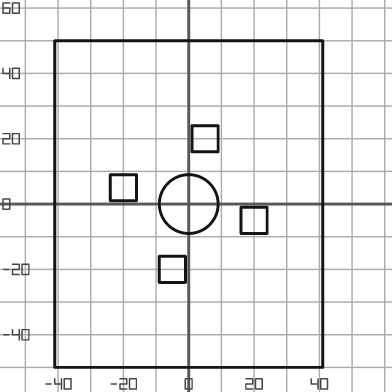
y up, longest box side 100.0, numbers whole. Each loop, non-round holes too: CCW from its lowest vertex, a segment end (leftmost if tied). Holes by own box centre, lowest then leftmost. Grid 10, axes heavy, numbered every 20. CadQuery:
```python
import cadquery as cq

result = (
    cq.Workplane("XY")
    .moveTo(-41.0, -50.0)
    .lineTo(41.0, -50.0)
    .lineTo(41.0, 50.0)
    .lineTo(-41.0, 50.0)
    .close()
    .moveTo(-9.0, -24.0)
    .lineTo(-1.0, -24.0)
    .lineTo(-1.0, -16.0)
    .lineTo(-9.0, -16.0)
    .close()
    .moveTo(16.0, -9.0)
    .lineTo(24.0, -9.0)
    .lineTo(24.0, -1.0)
    .lineTo(16.0, -1.0)
    .close()
    .moveTo(0.0, 0.0)
    .circle(9.0)
    .moveTo(-24.0, 1.0)
    .lineTo(-16.0, 1.0)
    .lineTo(-16.0, 9.0)
    .lineTo(-24.0, 9.0)
    .close()
    .moveTo(1.0, 16.0)
    .lineTo(9.0, 16.0)
    .lineTo(9.0, 24.0)
    .lineTo(1.0, 24.0)
    .close()
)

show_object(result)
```